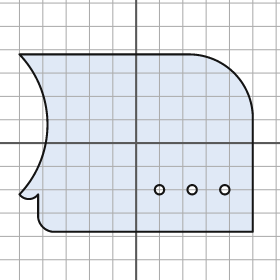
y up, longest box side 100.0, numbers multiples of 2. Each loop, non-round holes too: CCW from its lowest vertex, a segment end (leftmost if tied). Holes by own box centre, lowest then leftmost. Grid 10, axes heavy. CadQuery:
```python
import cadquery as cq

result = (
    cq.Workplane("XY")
    .moveTo(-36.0, -38.0)
    .lineTo(50.0, -38.0)
    .lineTo(50.0, 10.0)
    .threePointArc((42.0, 30.0), (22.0, 38.0))
    .lineTo(-50.0, 38.0)
    .threePointArc((-38.0, 8.0), (-50.0, -22.0))
    .threePointArc((-46.0, -24.0), (-42.0, -22.0))
    .lineTo(-42.0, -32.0)
    .threePointArc((-40.0, -36.0), (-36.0, -38.0))
    .close()
    .moveTo(10.0, -20.0)
    .circle(2.0)
    .moveTo(24.0, -20.0)
    .circle(2.0)
    .moveTo(38.0, -20.0)
    .circle(2.0)
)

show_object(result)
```